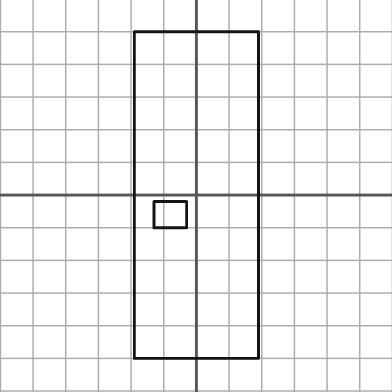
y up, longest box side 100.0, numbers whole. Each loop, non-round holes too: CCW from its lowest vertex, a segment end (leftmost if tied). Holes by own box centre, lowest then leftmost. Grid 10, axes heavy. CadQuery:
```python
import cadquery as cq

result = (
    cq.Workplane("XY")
    .moveTo(-19.0, -50.0)
    .lineTo(19.0, -50.0)
    .lineTo(19.0, 50.0)
    .lineTo(-19.0, 50.0)
    .close()
    .moveTo(-13.0, -10.0)
    .lineTo(-3.0, -10.0)
    .lineTo(-3.0, -2.0)
    .lineTo(-13.0, -2.0)
    .close()
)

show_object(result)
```